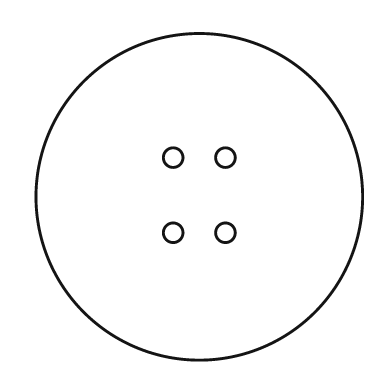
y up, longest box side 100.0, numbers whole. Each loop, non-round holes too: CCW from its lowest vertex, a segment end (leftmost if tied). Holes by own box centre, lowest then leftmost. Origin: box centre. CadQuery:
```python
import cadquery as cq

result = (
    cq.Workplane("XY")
    .moveTo(0.0, 0.0)
    .circle(50.0)
    .moveTo(-8.0, -11.0)
    .circle(3.0)
    .moveTo(8.0, -11.0)
    .circle(3.0)
    .moveTo(-8.0, 12.0)
    .circle(3.0)
    .moveTo(8.0, 12.0)
    .circle(3.0)
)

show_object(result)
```